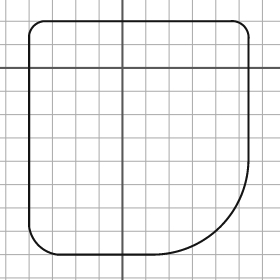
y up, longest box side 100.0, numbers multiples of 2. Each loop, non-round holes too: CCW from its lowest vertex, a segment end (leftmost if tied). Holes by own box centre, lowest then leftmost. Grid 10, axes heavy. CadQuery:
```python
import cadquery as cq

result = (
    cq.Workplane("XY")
    .moveTo(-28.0, -80.0)
    .lineTo(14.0, -80.0)
    .threePointArc((42.0, -68.0), (54.0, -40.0))
    .lineTo(54.0, 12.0)
    .threePointArc((52.0, 18.0), (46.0, 20.0))
    .lineTo(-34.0, 20.0)
    .threePointArc((-38.0, 18.0), (-40.0, 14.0))
    .lineTo(-40.0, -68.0)
    .threePointArc((-36.0, -76.0), (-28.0, -80.0))
    .close()
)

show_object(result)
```